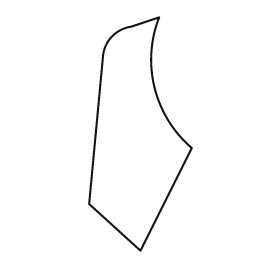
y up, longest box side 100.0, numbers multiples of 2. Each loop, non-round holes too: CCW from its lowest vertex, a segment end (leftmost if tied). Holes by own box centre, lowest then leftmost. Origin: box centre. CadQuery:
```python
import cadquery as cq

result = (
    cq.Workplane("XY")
    .moveTo(0.0, -50.0)
    .lineTo(22.0, -6.0)
    .threePointArc((6.0, 20.0), (8.0, 50.0))
    .lineTo(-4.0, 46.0)
    .threePointArc((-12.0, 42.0), (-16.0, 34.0))
    .lineTo(-22.0, -30.0)
    .close()
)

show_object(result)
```